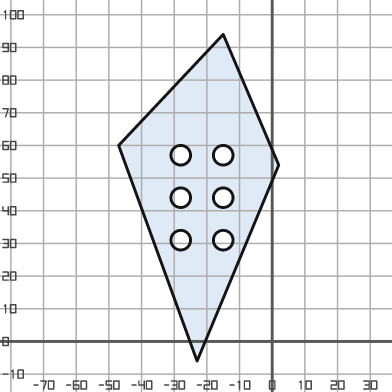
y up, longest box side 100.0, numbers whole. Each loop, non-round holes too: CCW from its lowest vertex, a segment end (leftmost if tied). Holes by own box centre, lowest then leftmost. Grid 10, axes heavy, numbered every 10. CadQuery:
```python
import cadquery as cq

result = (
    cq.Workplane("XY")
    .moveTo(-23.0, -6.0)
    .lineTo(2.0, 54.0)
    .lineTo(-15.0, 94.0)
    .lineTo(-47.0, 60.0)
    .close()
    .moveTo(-28.0, 31.0)
    .circle(3.0)
    .moveTo(-15.0, 31.0)
    .circle(3.0)
    .moveTo(-28.0, 44.0)
    .circle(3.0)
    .moveTo(-15.0, 44.0)
    .circle(3.0)
    .moveTo(-28.0, 57.0)
    .circle(3.0)
    .moveTo(-15.0, 57.0)
    .circle(3.0)
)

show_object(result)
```